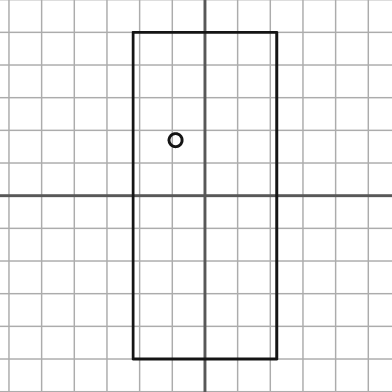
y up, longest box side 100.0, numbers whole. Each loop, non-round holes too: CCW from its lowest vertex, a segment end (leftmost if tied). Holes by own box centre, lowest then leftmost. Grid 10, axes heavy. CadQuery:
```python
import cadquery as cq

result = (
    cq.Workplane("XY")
    .moveTo(-22.0, -50.0)
    .lineTo(22.0, -50.0)
    .lineTo(22.0, 50.0)
    .lineTo(-22.0, 50.0)
    .close()
    .moveTo(-9.0, 17.0)
    .circle(2.0)
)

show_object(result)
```